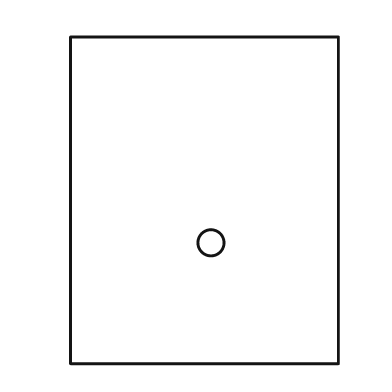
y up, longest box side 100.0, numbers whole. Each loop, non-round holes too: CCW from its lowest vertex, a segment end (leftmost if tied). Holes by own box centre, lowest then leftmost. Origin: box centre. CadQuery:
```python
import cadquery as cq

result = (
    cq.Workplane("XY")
    .moveTo(-41.0, -50.0)
    .lineTo(41.0, -50.0)
    .lineTo(41.0, 50.0)
    .lineTo(-41.0, 50.0)
    .close()
    .moveTo(2.0, -13.0)
    .circle(4.0)
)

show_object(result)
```